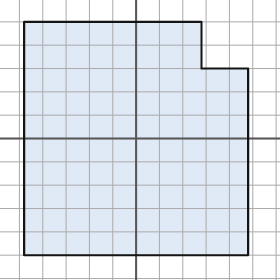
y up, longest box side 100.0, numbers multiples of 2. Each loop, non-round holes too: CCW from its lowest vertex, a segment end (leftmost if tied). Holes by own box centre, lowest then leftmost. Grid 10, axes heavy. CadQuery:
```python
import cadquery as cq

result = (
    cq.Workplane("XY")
    .moveTo(-48.0, -50.0)
    .lineTo(48.0, -50.0)
    .lineTo(48.0, 30.0)
    .lineTo(28.0, 30.0)
    .lineTo(28.0, 50.0)
    .lineTo(-48.0, 50.0)
    .close()
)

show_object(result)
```